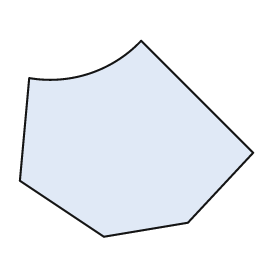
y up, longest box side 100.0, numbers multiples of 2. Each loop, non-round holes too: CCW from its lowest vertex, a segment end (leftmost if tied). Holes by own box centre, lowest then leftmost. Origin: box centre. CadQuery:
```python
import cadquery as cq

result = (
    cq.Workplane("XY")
    .moveTo(-14.0, -42.0)
    .lineTo(22.0, -36.0)
    .lineTo(50.0, -6.0)
    .lineTo(2.0, 42.0)
    .threePointArc((-20.0, 28.0), (-46.0, 26.0))
    .lineTo(-50.0, -18.0)
    .close()
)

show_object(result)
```